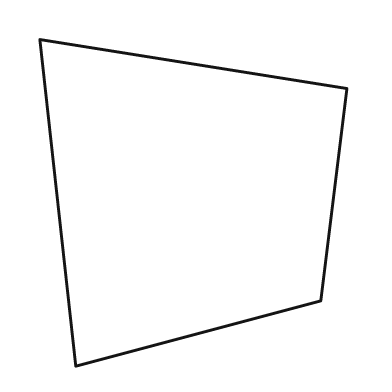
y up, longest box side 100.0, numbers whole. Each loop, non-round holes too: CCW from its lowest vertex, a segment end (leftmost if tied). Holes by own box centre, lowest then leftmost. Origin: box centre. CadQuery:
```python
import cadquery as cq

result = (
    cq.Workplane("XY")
    .moveTo(-36.0, -50.0)
    .lineTo(39.0, -30.0)
    .lineTo(47.0, 35.0)
    .lineTo(-47.0, 50.0)
    .close()
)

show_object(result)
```